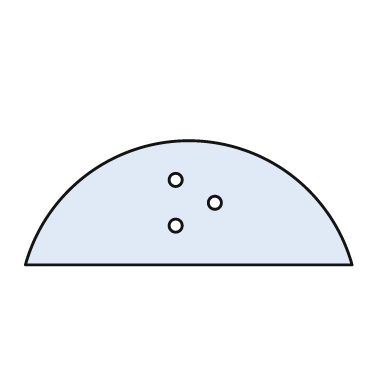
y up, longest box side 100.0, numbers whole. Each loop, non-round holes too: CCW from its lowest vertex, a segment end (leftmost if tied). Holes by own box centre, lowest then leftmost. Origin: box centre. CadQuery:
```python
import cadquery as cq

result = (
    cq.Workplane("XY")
    .moveTo(-50.0, -19.0)
    .lineTo(50.0, -19.0)
    .threePointArc((0.0, 19.0), (-50.0, -19.0))
    .close()
    .moveTo(-4.0, -7.0)
    .circle(2.0)
    .moveTo(8.0, 0.0)
    .circle(2.0)
    .moveTo(-4.0, 7.0)
    .circle(2.0)
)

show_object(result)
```